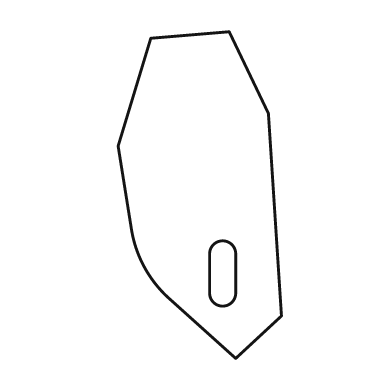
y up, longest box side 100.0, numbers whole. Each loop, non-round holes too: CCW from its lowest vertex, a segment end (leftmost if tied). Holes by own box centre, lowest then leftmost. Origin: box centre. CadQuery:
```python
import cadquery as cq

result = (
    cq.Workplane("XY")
    .moveTo(11.0, -50.0)
    .lineTo(25.0, -37.0)
    .lineTo(21.0, 25.0)
    .lineTo(9.0, 50.0)
    .lineTo(-15.0, 48.0)
    .lineTo(-25.0, 15.0)
    .lineTo(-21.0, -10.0)
    .threePointArc((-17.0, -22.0), (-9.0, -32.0))
    .close()
    .moveTo(3.0, -30.0)
    .threePointArc((7.0, -34.0), (11.0, -30.0))
    .lineTo(11.0, -18.0)
    .threePointArc((7.0, -14.0), (3.0, -18.0))
    .close()
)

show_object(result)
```